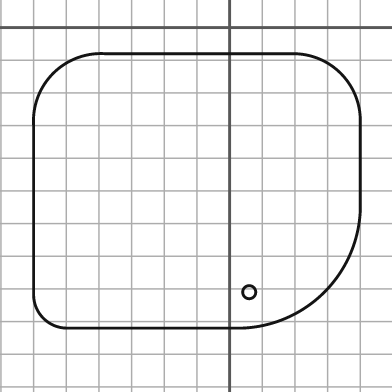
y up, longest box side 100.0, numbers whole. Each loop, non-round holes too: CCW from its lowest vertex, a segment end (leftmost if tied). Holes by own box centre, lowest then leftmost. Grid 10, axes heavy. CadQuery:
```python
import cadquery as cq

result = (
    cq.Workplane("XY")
    .moveTo(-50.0, -92.0)
    .lineTo(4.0, -92.0)
    .threePointArc((29.0, -81.0), (40.0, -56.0))
    .lineTo(40.0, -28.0)
    .threePointArc((34.0, -14.0), (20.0, -8.0))
    .lineTo(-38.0, -8.0)
    .threePointArc((-54.0, -14.0), (-60.0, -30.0))
    .lineTo(-60.0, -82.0)
    .threePointArc((-57.0, -89.0), (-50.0, -92.0))
    .close()
    .moveTo(6.0, -81.0)
    .circle(2.0)
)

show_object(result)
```